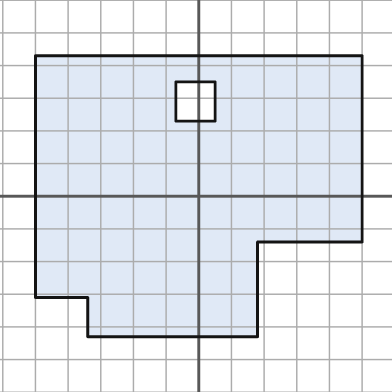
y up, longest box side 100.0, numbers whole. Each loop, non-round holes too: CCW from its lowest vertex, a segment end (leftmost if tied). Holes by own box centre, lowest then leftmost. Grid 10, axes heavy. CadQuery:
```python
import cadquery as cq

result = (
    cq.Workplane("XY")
    .moveTo(-34.0, -43.0)
    .lineTo(18.0, -43.0)
    .lineTo(18.0, -14.0)
    .lineTo(50.0, -14.0)
    .lineTo(50.0, 43.0)
    .lineTo(-50.0, 43.0)
    .lineTo(-50.0, -31.0)
    .lineTo(-34.0, -31.0)
    .close()
    .moveTo(-7.0, 23.0)
    .lineTo(5.0, 23.0)
    .lineTo(5.0, 35.0)
    .lineTo(-7.0, 35.0)
    .close()
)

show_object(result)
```